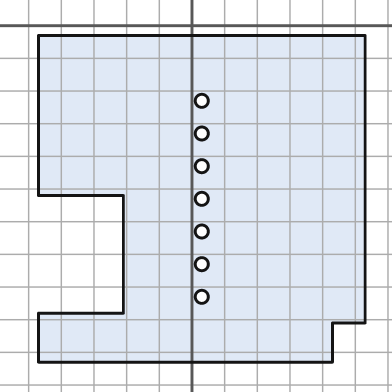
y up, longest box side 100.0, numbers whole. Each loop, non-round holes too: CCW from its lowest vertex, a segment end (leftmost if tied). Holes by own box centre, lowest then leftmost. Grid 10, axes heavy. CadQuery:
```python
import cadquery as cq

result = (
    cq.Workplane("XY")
    .moveTo(-47.0, -103.0)
    .lineTo(43.0, -103.0)
    .lineTo(43.0, -91.0)
    .lineTo(53.0, -91.0)
    .lineTo(53.0, -3.0)
    .lineTo(-47.0, -3.0)
    .lineTo(-47.0, -52.0)
    .lineTo(-21.0, -52.0)
    .lineTo(-21.0, -88.0)
    .lineTo(-47.0, -88.0)
    .close()
    .moveTo(3.0, -83.0)
    .circle(2.0)
    .moveTo(3.0, -73.0)
    .circle(2.0)
    .moveTo(3.0, -63.0)
    .circle(2.0)
    .moveTo(3.0, -53.0)
    .circle(2.0)
    .moveTo(3.0, -43.0)
    .circle(2.0)
    .moveTo(3.0, -33.0)
    .circle(2.0)
    .moveTo(3.0, -23.0)
    .circle(2.0)
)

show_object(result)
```